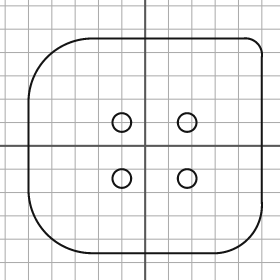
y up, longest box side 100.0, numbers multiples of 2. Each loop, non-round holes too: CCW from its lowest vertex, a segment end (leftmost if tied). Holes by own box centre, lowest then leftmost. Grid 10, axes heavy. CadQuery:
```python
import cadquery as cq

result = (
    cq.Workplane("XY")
    .moveTo(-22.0, -46.0)
    .lineTo(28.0, -46.0)
    .threePointArc((44.0, -40.0), (50.0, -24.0))
    .lineTo(50.0, 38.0)
    .threePointArc((48.0, 44.0), (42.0, 46.0))
    .lineTo(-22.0, 46.0)
    .threePointArc((-42.0, 38.0), (-50.0, 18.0))
    .lineTo(-50.0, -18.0)
    .threePointArc((-42.0, -38.0), (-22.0, -46.0))
    .close()
    .moveTo(-10.0, -14.0)
    .circle(4.0)
    .moveTo(18.0, -14.0)
    .circle(4.0)
    .moveTo(-10.0, 10.0)
    .circle(4.0)
    .moveTo(18.0, 10.0)
    .circle(4.0)
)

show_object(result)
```